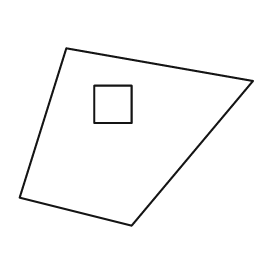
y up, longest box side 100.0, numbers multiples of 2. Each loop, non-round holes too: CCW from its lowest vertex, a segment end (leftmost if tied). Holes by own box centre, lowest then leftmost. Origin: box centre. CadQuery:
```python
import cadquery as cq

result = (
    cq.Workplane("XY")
    .moveTo(-2.0, -38.0)
    .lineTo(50.0, 24.0)
    .lineTo(-30.0, 38.0)
    .lineTo(-50.0, -26.0)
    .close()
    .moveTo(-18.0, 6.0)
    .lineTo(-2.0, 6.0)
    .lineTo(-2.0, 22.0)
    .lineTo(-18.0, 22.0)
    .close()
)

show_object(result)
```